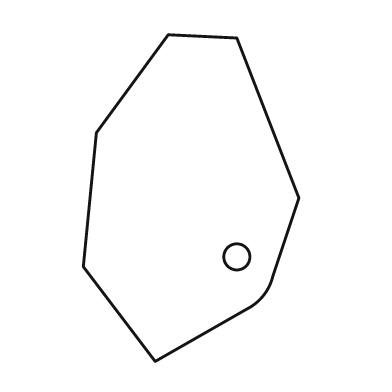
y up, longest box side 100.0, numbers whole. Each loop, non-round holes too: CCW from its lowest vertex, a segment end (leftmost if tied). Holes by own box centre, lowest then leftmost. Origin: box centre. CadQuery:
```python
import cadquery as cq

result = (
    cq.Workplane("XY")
    .moveTo(-11.0, -50.0)
    .lineTo(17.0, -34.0)
    .threePointArc((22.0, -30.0), (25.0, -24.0))
    .lineTo(33.0, 0.0)
    .lineTo(14.0, 49.0)
    .lineTo(-7.0, 50.0)
    .lineTo(-29.0, 20.0)
    .lineTo(-33.0, -21.0)
    .close()
    .moveTo(14.0, -18.0)
    .circle(4.0)
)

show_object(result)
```